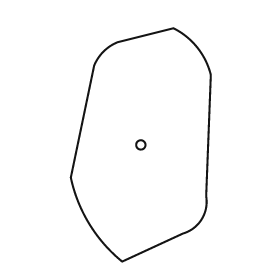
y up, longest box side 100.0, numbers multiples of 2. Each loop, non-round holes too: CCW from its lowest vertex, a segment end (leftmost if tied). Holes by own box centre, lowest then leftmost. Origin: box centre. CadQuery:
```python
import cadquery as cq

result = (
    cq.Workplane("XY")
    .moveTo(-8.0, -50.0)
    .lineTo(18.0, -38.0)
    .threePointArc((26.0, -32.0), (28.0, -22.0))
    .lineTo(30.0, 30.0)
    .threePointArc((24.0, 42.0), (14.0, 50.0))
    .lineTo(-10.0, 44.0)
    .threePointArc((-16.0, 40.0), (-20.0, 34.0))
    .lineTo(-30.0, -14.0)
    .threePointArc((-22.0, -34.0), (-8.0, -50.0))
    .close()
    .moveTo(0.0, 0.0)
    .circle(2.0)
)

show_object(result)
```